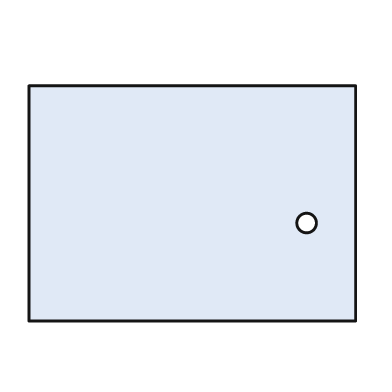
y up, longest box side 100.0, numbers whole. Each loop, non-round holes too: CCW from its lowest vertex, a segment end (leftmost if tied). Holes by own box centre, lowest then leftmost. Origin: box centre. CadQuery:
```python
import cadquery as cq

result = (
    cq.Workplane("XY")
    .moveTo(-50.0, -36.0)
    .lineTo(50.0, -36.0)
    .lineTo(50.0, 36.0)
    .lineTo(-50.0, 36.0)
    .close()
    .moveTo(35.0, -6.0)
    .circle(3.0)
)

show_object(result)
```